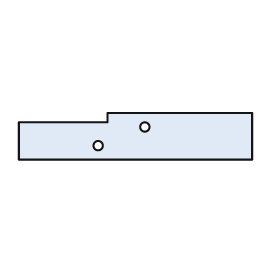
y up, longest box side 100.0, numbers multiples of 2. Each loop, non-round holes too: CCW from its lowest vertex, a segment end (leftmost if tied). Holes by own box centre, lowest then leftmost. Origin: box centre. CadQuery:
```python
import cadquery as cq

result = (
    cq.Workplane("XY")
    .moveTo(-50.0, -10.0)
    .lineTo(50.0, -10.0)
    .lineTo(50.0, 10.0)
    .lineTo(-12.0, 10.0)
    .lineTo(-12.0, 6.0)
    .lineTo(-50.0, 6.0)
    .close()
    .moveTo(-16.0, -4.0)
    .circle(2.0)
    .moveTo(4.0, 4.0)
    .circle(2.0)
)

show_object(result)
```